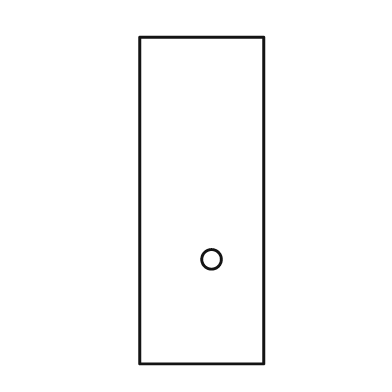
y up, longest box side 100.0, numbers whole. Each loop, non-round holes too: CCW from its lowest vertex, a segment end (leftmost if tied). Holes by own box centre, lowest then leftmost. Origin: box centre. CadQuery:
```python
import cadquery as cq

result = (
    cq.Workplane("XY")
    .moveTo(-19.0, -50.0)
    .lineTo(19.0, -50.0)
    .lineTo(19.0, 50.0)
    .lineTo(-19.0, 50.0)
    .close()
    .moveTo(3.0, -18.0)
    .circle(3.0)
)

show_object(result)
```